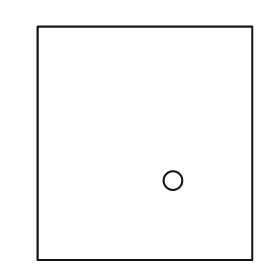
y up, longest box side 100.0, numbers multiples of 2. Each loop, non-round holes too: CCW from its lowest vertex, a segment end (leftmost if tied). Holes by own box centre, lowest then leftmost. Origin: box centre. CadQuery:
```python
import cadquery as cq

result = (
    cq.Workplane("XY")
    .moveTo(-46.0, -50.0)
    .lineTo(46.0, -50.0)
    .lineTo(46.0, 50.0)
    .lineTo(-46.0, 50.0)
    .close()
    .moveTo(12.0, -16.0)
    .circle(4.0)
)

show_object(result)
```